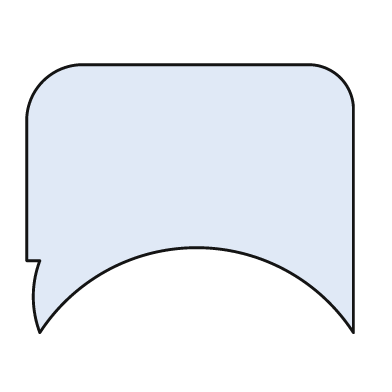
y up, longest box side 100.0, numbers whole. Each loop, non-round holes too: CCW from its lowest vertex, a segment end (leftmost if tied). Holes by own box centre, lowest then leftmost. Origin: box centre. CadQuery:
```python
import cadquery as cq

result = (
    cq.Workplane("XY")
    .moveTo(-46.0, -41.0)
    .threePointArc((2.0, -15.0), (50.0, -41.0))
    .lineTo(50.0, 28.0)
    .threePointArc((46.0, 37.0), (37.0, 41.0))
    .lineTo(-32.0, 41.0)
    .threePointArc((-45.0, 36.0), (-50.0, 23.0))
    .lineTo(-50.0, -19.0)
    .lineTo(-46.0, -19.0)
    .threePointArc((-48.0, -30.0), (-46.0, -41.0))
    .close()
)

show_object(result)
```